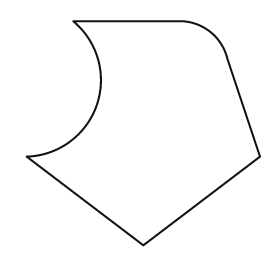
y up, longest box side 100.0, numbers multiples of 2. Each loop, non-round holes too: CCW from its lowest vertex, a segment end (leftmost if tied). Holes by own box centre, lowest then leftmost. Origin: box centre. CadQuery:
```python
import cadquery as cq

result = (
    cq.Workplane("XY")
    .moveTo(0.0, -48.0)
    .lineTo(50.0, -10.0)
    .lineTo(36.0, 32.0)
    .threePointArc((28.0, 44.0), (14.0, 48.0))
    .lineTo(-30.0, 48.0)
    .threePointArc((-20.0, 12.0), (-50.0, -10.0))
    .close()
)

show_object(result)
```